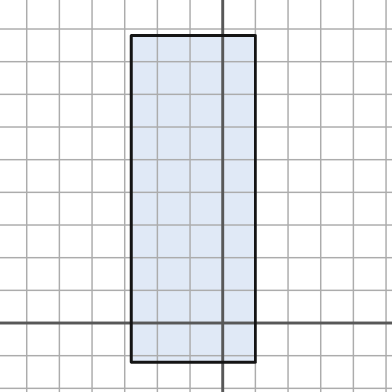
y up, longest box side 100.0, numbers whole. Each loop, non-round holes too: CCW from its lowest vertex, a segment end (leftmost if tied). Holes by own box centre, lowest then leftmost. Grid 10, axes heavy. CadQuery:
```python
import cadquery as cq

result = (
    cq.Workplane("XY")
    .moveTo(-28.0, -12.0)
    .lineTo(10.0, -12.0)
    .lineTo(10.0, 88.0)
    .lineTo(-28.0, 88.0)
    .close()
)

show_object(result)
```